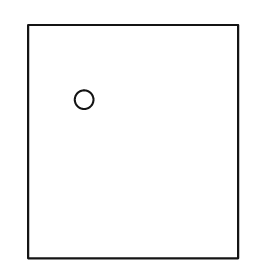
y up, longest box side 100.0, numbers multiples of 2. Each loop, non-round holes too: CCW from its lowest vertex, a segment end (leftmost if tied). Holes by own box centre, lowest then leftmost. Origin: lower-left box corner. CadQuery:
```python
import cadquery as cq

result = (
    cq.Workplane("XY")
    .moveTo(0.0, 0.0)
    .lineTo(90.0, 0.0)
    .lineTo(90.0, 100.0)
    .lineTo(0.0, 100.0)
    .close()
    .moveTo(24.0, 68.0)
    .circle(4.0)
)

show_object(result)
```